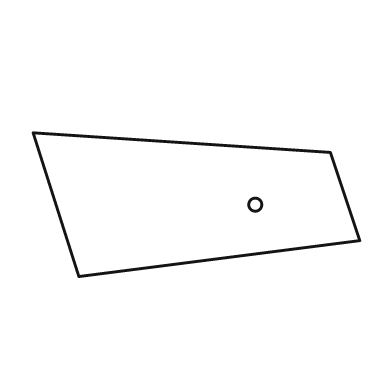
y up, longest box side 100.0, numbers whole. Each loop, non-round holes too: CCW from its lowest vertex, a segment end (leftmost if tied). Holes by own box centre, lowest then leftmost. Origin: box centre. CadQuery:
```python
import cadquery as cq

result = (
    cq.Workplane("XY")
    .moveTo(-36.0, -22.0)
    .lineTo(50.0, -11.0)
    .lineTo(41.0, 16.0)
    .lineTo(-50.0, 22.0)
    .close()
    .moveTo(18.0, 0.0)
    .circle(2.0)
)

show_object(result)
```